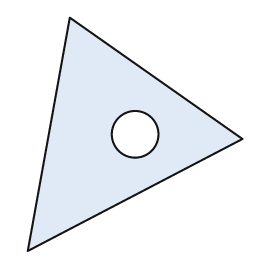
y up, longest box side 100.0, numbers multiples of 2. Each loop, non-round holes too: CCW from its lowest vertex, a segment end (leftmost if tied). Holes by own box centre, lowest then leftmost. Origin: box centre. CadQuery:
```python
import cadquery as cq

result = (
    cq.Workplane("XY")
    .moveTo(-46.0, -50.0)
    .lineTo(46.0, -2.0)
    .lineTo(-28.0, 50.0)
    .close()
    .moveTo(0.0, 0.0)
    .circle(10.0)
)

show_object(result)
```